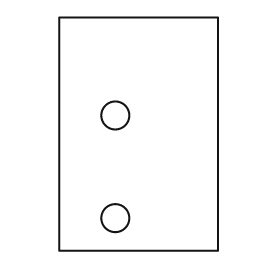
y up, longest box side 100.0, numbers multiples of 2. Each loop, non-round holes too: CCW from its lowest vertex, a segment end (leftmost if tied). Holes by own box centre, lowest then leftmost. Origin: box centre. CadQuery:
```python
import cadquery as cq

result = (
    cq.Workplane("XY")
    .moveTo(-34.0, -50.0)
    .lineTo(34.0, -50.0)
    .lineTo(34.0, 50.0)
    .lineTo(-34.0, 50.0)
    .close()
    .moveTo(-10.0, -36.0)
    .circle(6.0)
    .moveTo(-10.0, 8.0)
    .circle(6.0)
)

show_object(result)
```